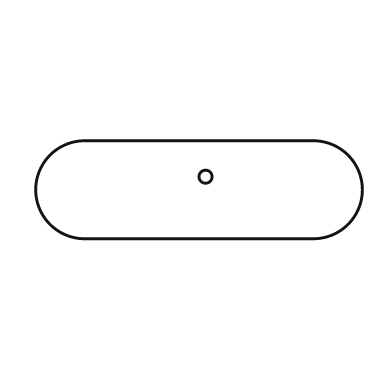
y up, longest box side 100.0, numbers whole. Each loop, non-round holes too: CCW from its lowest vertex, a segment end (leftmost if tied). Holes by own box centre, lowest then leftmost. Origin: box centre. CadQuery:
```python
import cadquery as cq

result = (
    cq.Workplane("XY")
    .moveTo(-35.0, -15.0)
    .lineTo(35.0, -15.0)
    .threePointArc((50.0, 0.0), (35.0, 15.0))
    .lineTo(-35.0, 15.0)
    .threePointArc((-50.0, 0.0), (-35.0, -15.0))
    .close()
    .moveTo(2.0, 4.0)
    .circle(2.0)
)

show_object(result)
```